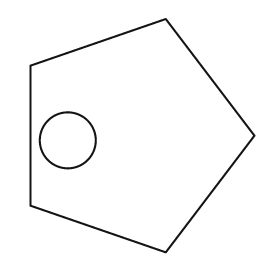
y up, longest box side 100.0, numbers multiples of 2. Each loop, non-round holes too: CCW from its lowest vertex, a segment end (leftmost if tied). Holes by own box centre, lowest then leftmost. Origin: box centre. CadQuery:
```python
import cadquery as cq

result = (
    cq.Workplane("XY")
    .moveTo(10.0, -50.0)
    .lineTo(48.0, 0.0)
    .lineTo(10.0, 50.0)
    .lineTo(-48.0, 30.0)
    .lineTo(-48.0, -30.0)
    .close()
    .moveTo(-32.0, -2.0)
    .circle(12.0)
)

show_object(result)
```